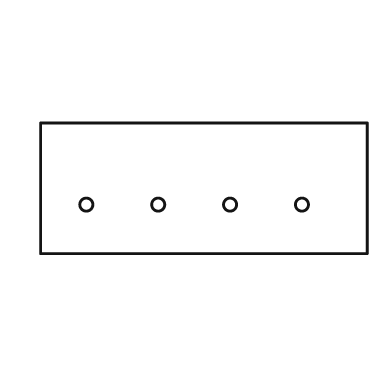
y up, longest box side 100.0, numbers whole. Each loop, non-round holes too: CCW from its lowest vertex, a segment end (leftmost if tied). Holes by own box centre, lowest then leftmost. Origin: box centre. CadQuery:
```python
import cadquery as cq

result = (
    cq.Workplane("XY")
    .moveTo(-50.0, -20.0)
    .lineTo(50.0, -20.0)
    .lineTo(50.0, 20.0)
    .lineTo(-50.0, 20.0)
    .close()
    .moveTo(-36.0, -5.0)
    .circle(2.0)
    .moveTo(-14.0, -5.0)
    .circle(2.0)
    .moveTo(8.0, -5.0)
    .circle(2.0)
    .moveTo(30.0, -5.0)
    .circle(2.0)
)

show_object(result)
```